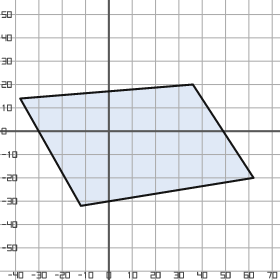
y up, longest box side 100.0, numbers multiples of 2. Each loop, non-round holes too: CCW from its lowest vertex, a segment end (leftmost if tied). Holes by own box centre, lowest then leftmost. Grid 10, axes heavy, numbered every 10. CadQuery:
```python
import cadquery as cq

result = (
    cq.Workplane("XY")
    .moveTo(-12.0, -32.0)
    .lineTo(62.0, -20.0)
    .lineTo(36.0, 20.0)
    .lineTo(-38.0, 14.0)
    .close()
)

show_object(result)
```